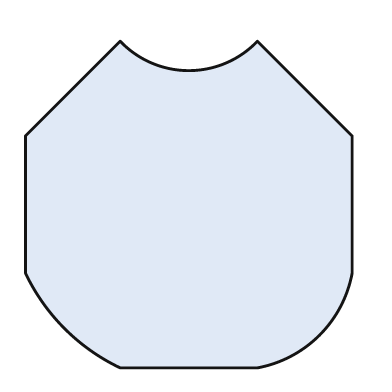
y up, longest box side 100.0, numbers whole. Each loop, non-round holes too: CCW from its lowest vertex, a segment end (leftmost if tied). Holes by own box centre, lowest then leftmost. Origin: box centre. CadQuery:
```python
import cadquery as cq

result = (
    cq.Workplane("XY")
    .moveTo(-21.0, -50.0)
    .lineTo(21.0, -50.0)
    .threePointArc((40.0, -40.0), (50.0, -21.0))
    .lineTo(50.0, 21.0)
    .lineTo(21.0, 50.0)
    .threePointArc((0.0, 41.0), (-21.0, 50.0))
    .lineTo(-50.0, 21.0)
    .lineTo(-50.0, -21.0)
    .threePointArc((-38.0, -38.0), (-21.0, -50.0))
    .close()
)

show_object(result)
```